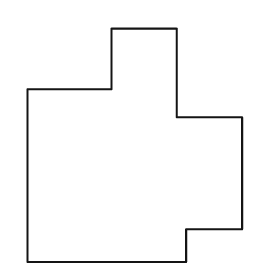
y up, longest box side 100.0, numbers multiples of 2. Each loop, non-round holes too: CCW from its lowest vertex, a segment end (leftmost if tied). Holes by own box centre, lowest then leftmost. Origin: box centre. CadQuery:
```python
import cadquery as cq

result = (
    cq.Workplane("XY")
    .moveTo(-46.0, -50.0)
    .lineTo(22.0, -50.0)
    .lineTo(22.0, -36.0)
    .lineTo(46.0, -36.0)
    .lineTo(46.0, 12.0)
    .lineTo(18.0, 12.0)
    .lineTo(18.0, 50.0)
    .lineTo(-10.0, 50.0)
    .lineTo(-10.0, 24.0)
    .lineTo(-46.0, 24.0)
    .close()
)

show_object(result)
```